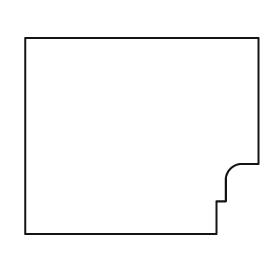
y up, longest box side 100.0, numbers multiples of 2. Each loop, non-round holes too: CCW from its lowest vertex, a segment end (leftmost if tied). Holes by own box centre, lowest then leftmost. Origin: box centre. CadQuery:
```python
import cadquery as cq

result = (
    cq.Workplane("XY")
    .moveTo(-50.0, -42.0)
    .lineTo(32.0, -42.0)
    .lineTo(32.0, -28.0)
    .lineTo(36.0, -28.0)
    .lineTo(36.0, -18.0)
    .threePointArc((38.0, -14.0), (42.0, -12.0))
    .lineTo(50.0, -12.0)
    .lineTo(50.0, 42.0)
    .lineTo(-50.0, 42.0)
    .close()
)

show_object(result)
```